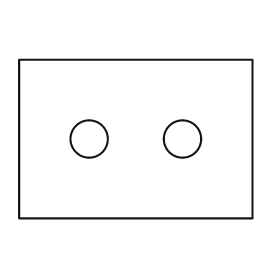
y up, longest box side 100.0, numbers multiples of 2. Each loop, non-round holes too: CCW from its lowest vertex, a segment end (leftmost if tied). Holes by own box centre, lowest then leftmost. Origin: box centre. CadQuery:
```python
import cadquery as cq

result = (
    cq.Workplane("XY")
    .moveTo(-50.0, -34.0)
    .lineTo(50.0, -34.0)
    .lineTo(50.0, 34.0)
    .lineTo(-50.0, 34.0)
    .close()
    .moveTo(-20.0, 0.0)
    .circle(8.0)
    .moveTo(20.0, 0.0)
    .circle(8.0)
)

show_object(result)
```